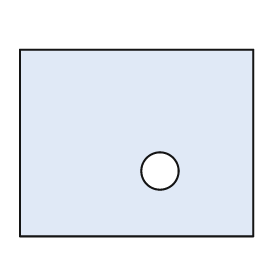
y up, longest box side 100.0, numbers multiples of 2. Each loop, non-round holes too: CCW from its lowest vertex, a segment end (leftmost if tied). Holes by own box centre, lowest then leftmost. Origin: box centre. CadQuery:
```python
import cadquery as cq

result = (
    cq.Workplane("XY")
    .moveTo(-50.0, -40.0)
    .lineTo(50.0, -40.0)
    .lineTo(50.0, 40.0)
    .lineTo(-50.0, 40.0)
    .close()
    .moveTo(10.0, -12.0)
    .circle(8.0)
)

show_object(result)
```